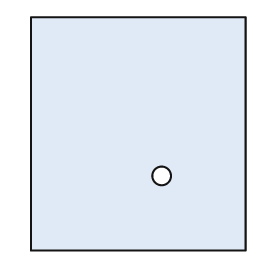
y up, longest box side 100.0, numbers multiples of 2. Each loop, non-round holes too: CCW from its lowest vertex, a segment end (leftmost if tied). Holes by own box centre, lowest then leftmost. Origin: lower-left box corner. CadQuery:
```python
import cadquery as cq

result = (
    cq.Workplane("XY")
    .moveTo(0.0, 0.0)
    .lineTo(92.0, 0.0)
    .lineTo(92.0, 100.0)
    .lineTo(0.0, 100.0)
    .close()
    .moveTo(56.0, 32.0)
    .circle(4.0)
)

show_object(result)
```